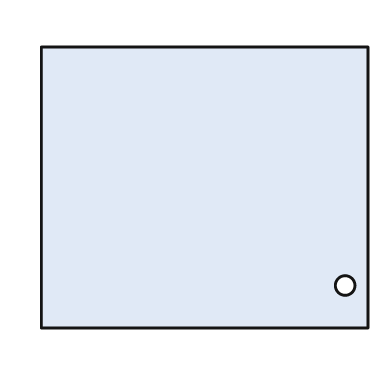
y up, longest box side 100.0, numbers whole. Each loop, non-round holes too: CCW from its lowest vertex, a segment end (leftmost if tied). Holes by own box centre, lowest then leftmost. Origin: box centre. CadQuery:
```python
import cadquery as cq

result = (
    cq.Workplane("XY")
    .moveTo(-50.0, -43.0)
    .lineTo(50.0, -43.0)
    .lineTo(50.0, 43.0)
    .lineTo(-50.0, 43.0)
    .close()
    .moveTo(43.0, -30.0)
    .circle(3.0)
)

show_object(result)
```